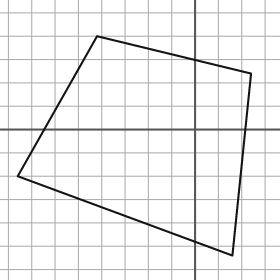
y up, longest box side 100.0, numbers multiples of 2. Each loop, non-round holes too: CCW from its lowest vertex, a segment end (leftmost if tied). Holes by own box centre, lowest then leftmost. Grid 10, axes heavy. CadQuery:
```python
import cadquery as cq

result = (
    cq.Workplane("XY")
    .moveTo(16.0, -54.0)
    .lineTo(24.0, 24.0)
    .lineTo(-42.0, 40.0)
    .lineTo(-76.0, -20.0)
    .close()
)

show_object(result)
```